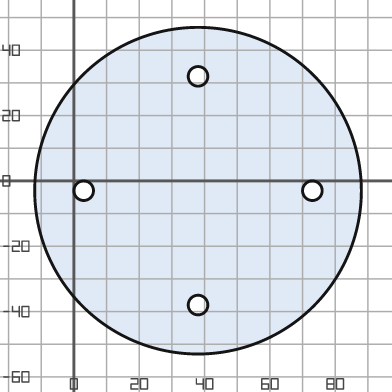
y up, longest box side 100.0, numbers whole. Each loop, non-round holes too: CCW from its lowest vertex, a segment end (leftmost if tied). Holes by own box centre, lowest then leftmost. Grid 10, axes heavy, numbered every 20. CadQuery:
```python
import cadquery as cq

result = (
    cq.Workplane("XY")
    .moveTo(38.0, -3.0)
    .circle(50.0)
    .moveTo(38.0, -38.0)
    .circle(3.0)
    .moveTo(3.0, -3.0)
    .circle(3.0)
    .moveTo(73.0, -3.0)
    .circle(3.0)
    .moveTo(38.0, 32.0)
    .circle(3.0)
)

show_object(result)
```